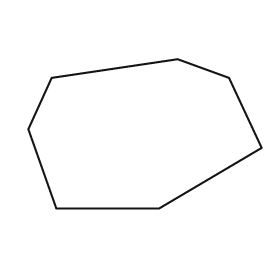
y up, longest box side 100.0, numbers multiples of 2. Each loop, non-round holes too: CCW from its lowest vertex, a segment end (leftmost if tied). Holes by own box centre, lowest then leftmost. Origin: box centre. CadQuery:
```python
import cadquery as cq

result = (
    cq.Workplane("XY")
    .moveTo(-38.0, -32.0)
    .lineTo(6.0, -32.0)
    .lineTo(50.0, -6.0)
    .lineTo(36.0, 24.0)
    .lineTo(14.0, 32.0)
    .lineTo(-40.0, 24.0)
    .lineTo(-50.0, 2.0)
    .close()
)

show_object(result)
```